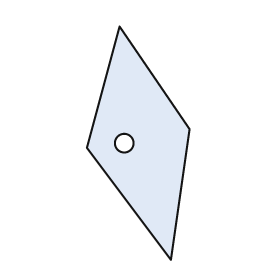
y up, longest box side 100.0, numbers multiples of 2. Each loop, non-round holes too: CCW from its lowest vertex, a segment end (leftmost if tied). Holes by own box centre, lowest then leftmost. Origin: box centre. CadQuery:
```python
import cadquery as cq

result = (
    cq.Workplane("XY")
    .moveTo(14.0, -50.0)
    .lineTo(22.0, 6.0)
    .lineTo(-8.0, 50.0)
    .lineTo(-22.0, -2.0)
    .close()
    .moveTo(-6.0, 0.0)
    .circle(4.0)
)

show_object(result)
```